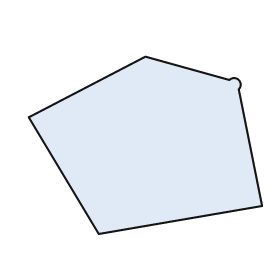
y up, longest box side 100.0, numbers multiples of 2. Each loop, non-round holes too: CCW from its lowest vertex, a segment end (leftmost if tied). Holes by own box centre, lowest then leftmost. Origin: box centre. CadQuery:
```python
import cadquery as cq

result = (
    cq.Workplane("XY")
    .moveTo(-20.0, -38.0)
    .lineTo(50.0, -26.0)
    .lineTo(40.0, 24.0)
    .threePointArc((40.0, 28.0), (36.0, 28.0))
    .lineTo(0.0, 38.0)
    .lineTo(-50.0, 12.0)
    .close()
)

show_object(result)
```